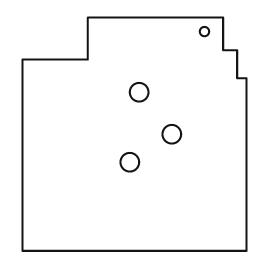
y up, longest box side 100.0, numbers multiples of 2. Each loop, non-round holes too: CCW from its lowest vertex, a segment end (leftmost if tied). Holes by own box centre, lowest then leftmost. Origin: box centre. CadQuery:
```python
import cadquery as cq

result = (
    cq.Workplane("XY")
    .moveTo(-48.0, -50.0)
    .lineTo(48.0, -50.0)
    .lineTo(48.0, 24.0)
    .lineTo(44.0, 24.0)
    .lineTo(44.0, 36.0)
    .lineTo(38.0, 36.0)
    .lineTo(38.0, 50.0)
    .lineTo(-20.0, 50.0)
    .lineTo(-20.0, 32.0)
    .lineTo(-48.0, 32.0)
    .close()
    .moveTo(-2.0, -12.0)
    .circle(4.0)
    .moveTo(16.0, 0.0)
    .circle(4.0)
    .moveTo(2.0, 18.0)
    .circle(4.0)
    .moveTo(30.0, 44.0)
    .circle(2.0)
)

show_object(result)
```